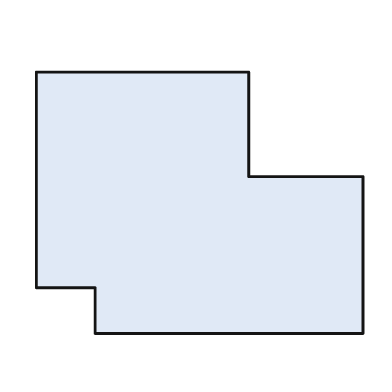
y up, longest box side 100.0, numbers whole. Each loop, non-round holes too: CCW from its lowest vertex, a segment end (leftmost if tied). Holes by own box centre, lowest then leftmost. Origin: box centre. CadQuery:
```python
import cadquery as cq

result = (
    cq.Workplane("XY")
    .moveTo(-32.0, -40.0)
    .lineTo(50.0, -40.0)
    .lineTo(50.0, 8.0)
    .lineTo(15.0, 8.0)
    .lineTo(15.0, 40.0)
    .lineTo(-50.0, 40.0)
    .lineTo(-50.0, -26.0)
    .lineTo(-32.0, -26.0)
    .close()
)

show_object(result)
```